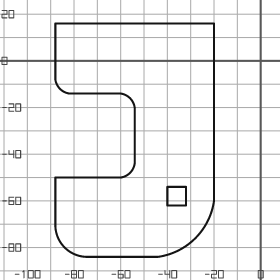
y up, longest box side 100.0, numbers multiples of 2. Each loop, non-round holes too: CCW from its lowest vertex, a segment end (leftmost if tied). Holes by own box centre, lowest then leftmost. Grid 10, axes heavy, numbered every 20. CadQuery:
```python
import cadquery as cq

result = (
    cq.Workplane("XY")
    .moveTo(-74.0, -84.0)
    .lineTo(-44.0, -84.0)
    .threePointArc((-28.0, -76.0), (-20.0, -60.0))
    .lineTo(-20.0, 16.0)
    .lineTo(-88.0, 16.0)
    .lineTo(-88.0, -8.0)
    .threePointArc((-86.0, -12.0), (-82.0, -14.0))
    .lineTo(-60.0, -14.0)
    .threePointArc((-56.0, -16.0), (-54.0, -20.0))
    .lineTo(-54.0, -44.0)
    .threePointArc((-56.0, -48.0), (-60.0, -50.0))
    .lineTo(-88.0, -50.0)
    .lineTo(-88.0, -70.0)
    .threePointArc((-84.0, -80.0), (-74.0, -84.0))
    .close()
    .moveTo(-40.0, -62.0)
    .lineTo(-32.0, -62.0)
    .lineTo(-32.0, -54.0)
    .lineTo(-40.0, -54.0)
    .close()
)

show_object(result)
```